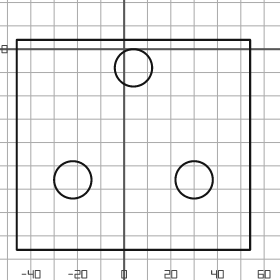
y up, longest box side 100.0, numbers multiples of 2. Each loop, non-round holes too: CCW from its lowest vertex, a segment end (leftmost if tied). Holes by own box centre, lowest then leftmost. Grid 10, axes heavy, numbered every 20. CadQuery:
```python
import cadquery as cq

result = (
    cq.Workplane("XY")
    .moveTo(-46.0, -86.0)
    .lineTo(54.0, -86.0)
    .lineTo(54.0, 4.0)
    .lineTo(-46.0, 4.0)
    .close()
    .moveTo(-22.0, -56.0)
    .circle(8.0)
    .moveTo(30.0, -56.0)
    .circle(8.0)
    .moveTo(4.0, -8.0)
    .circle(8.0)
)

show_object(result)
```